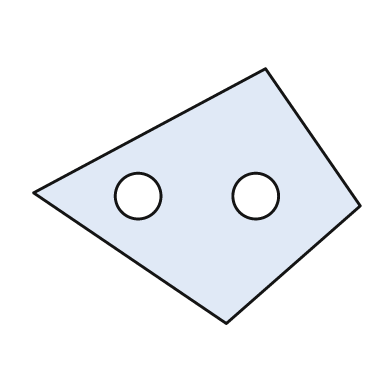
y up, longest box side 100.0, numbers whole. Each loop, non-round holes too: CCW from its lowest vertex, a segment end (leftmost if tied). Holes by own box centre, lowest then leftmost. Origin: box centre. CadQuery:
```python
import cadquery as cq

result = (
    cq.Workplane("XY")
    .moveTo(9.0, -39.0)
    .lineTo(50.0, -3.0)
    .lineTo(21.0, 39.0)
    .lineTo(-50.0, 1.0)
    .close()
    .moveTo(-18.0, 0.0)
    .circle(7.0)
    .moveTo(18.0, 0.0)
    .circle(7.0)
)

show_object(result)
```